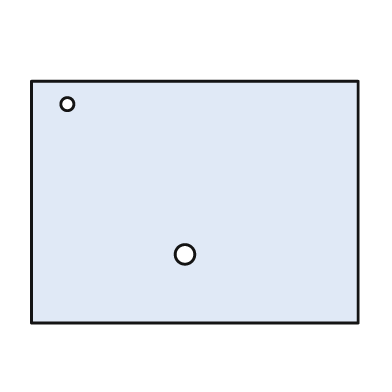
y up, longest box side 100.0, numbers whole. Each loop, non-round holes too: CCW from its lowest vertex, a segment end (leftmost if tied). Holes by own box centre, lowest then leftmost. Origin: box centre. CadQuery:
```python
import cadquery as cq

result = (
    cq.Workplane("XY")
    .moveTo(-50.0, -37.0)
    .lineTo(50.0, -37.0)
    .lineTo(50.0, 37.0)
    .lineTo(-50.0, 37.0)
    .close()
    .moveTo(-3.0, -16.0)
    .circle(3.0)
    .moveTo(-39.0, 30.0)
    .circle(2.0)
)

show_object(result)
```